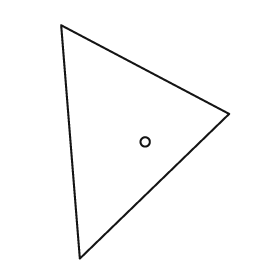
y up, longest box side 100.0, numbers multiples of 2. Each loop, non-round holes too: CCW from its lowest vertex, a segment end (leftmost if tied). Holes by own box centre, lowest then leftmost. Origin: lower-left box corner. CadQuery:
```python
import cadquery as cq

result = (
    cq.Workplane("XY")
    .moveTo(8.0, 0.0)
    .lineTo(72.0, 62.0)
    .lineTo(0.0, 100.0)
    .close()
    .moveTo(36.0, 50.0)
    .circle(2.0)
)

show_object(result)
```